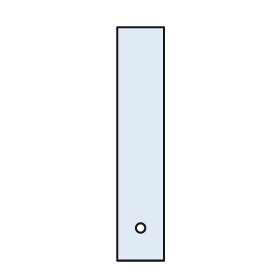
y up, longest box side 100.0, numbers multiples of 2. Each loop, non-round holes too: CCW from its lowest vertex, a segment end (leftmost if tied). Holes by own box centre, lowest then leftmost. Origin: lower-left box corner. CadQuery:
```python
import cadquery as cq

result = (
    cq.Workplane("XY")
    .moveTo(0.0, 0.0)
    .lineTo(20.0, 0.0)
    .lineTo(20.0, 100.0)
    .lineTo(0.0, 100.0)
    .close()
    .moveTo(10.0, 14.0)
    .circle(2.0)
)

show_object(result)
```